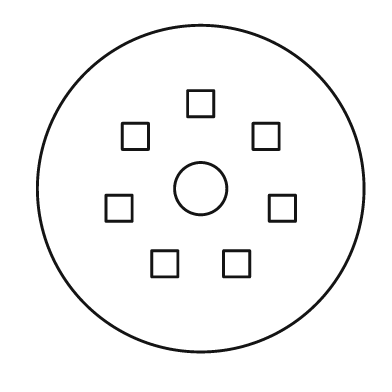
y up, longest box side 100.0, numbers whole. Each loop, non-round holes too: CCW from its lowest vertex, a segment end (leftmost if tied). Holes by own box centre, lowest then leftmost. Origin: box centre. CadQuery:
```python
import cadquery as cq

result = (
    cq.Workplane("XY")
    .moveTo(0.0, 0.0)
    .circle(50.0)
    .moveTo(-15.0, -27.0)
    .lineTo(-7.0, -27.0)
    .lineTo(-7.0, -19.0)
    .lineTo(-15.0, -19.0)
    .close()
    .moveTo(7.0, -27.0)
    .lineTo(15.0, -27.0)
    .lineTo(15.0, -19.0)
    .lineTo(7.0, -19.0)
    .close()
    .moveTo(-29.0, -10.0)
    .lineTo(-21.0, -10.0)
    .lineTo(-21.0, -2.0)
    .lineTo(-29.0, -2.0)
    .close()
    .moveTo(21.0, -10.0)
    .lineTo(29.0, -10.0)
    .lineTo(29.0, -2.0)
    .lineTo(21.0, -2.0)
    .close()
    .moveTo(0.0, 0.0)
    .circle(8.0)
    .moveTo(-24.0, 12.0)
    .lineTo(-16.0, 12.0)
    .lineTo(-16.0, 20.0)
    .lineTo(-24.0, 20.0)
    .close()
    .moveTo(16.0, 12.0)
    .lineTo(24.0, 12.0)
    .lineTo(24.0, 20.0)
    .lineTo(16.0, 20.0)
    .close()
    .moveTo(-4.0, 22.0)
    .lineTo(4.0, 22.0)
    .lineTo(4.0, 30.0)
    .lineTo(-4.0, 30.0)
    .close()
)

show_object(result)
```